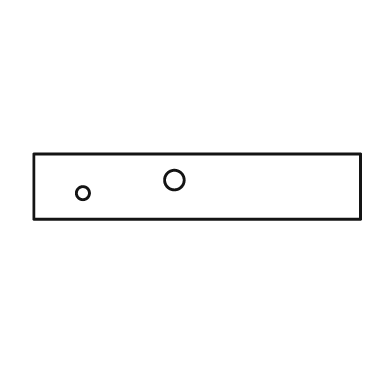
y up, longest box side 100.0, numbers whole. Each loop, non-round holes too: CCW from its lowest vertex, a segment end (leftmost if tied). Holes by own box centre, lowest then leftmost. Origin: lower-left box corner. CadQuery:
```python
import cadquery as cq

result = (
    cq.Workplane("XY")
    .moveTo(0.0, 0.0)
    .lineTo(100.0, 0.0)
    .lineTo(100.0, 20.0)
    .lineTo(0.0, 20.0)
    .close()
    .moveTo(15.0, 8.0)
    .circle(2.0)
    .moveTo(43.0, 12.0)
    .circle(3.0)
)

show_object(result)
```